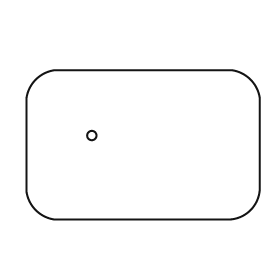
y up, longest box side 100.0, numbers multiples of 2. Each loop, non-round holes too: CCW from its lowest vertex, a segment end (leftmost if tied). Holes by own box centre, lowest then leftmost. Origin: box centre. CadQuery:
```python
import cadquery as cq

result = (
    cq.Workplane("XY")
    .moveTo(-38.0, -32.0)
    .lineTo(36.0, -32.0)
    .threePointArc((46.0, -28.0), (50.0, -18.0))
    .lineTo(50.0, 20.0)
    .threePointArc((46.0, 28.0), (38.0, 32.0))
    .lineTo(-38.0, 32.0)
    .threePointArc((-46.0, 28.0), (-50.0, 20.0))
    .lineTo(-50.0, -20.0)
    .threePointArc((-46.0, -28.0), (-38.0, -32.0))
    .close()
    .moveTo(-22.0, 4.0)
    .circle(2.0)
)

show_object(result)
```